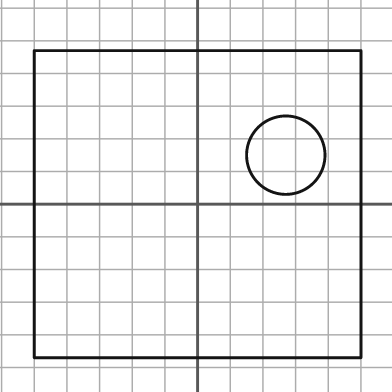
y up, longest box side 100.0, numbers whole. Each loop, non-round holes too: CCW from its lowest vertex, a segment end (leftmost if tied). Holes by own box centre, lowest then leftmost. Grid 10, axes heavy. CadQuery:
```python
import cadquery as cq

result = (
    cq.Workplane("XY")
    .moveTo(-50.0, -47.0)
    .lineTo(50.0, -47.0)
    .lineTo(50.0, 47.0)
    .lineTo(-50.0, 47.0)
    .close()
    .moveTo(27.0, 15.0)
    .circle(12.0)
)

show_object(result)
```